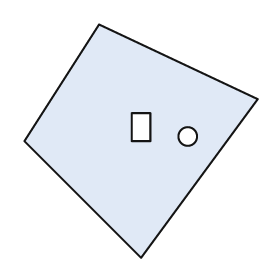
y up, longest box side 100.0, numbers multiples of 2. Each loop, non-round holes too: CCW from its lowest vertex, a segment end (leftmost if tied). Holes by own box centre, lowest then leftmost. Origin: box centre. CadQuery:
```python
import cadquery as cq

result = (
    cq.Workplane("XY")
    .moveTo(0.0, -50.0)
    .lineTo(50.0, 18.0)
    .lineTo(-18.0, 50.0)
    .lineTo(-50.0, 0.0)
    .close()
    .moveTo(20.0, 2.0)
    .circle(4.0)
    .moveTo(-4.0, 0.0)
    .lineTo(4.0, 0.0)
    .lineTo(4.0, 12.0)
    .lineTo(-4.0, 12.0)
    .close()
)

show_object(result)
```